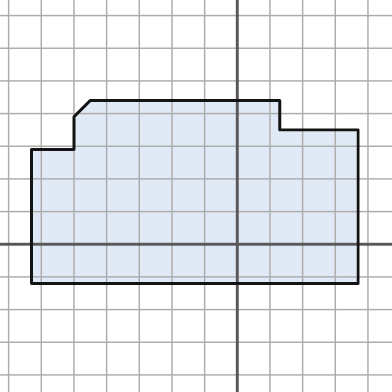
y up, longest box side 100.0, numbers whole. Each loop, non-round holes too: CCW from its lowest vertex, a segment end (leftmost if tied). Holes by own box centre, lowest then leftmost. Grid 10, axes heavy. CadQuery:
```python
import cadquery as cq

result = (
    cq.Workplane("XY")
    .moveTo(-63.0, -12.0)
    .lineTo(37.0, -12.0)
    .lineTo(37.0, 35.0)
    .lineTo(13.0, 35.0)
    .lineTo(13.0, 44.0)
    .lineTo(-45.0, 44.0)
    .lineTo(-50.0, 39.0)
    .lineTo(-50.0, 29.0)
    .lineTo(-63.0, 29.0)
    .close()
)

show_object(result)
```